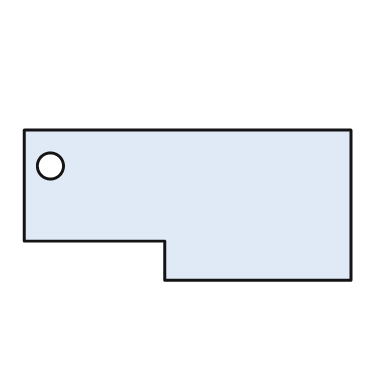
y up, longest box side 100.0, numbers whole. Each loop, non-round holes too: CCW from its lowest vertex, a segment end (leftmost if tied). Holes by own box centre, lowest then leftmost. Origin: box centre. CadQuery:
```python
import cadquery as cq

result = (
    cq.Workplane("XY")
    .moveTo(-7.0, -23.0)
    .lineTo(50.0, -23.0)
    .lineTo(50.0, 23.0)
    .lineTo(-50.0, 23.0)
    .lineTo(-50.0, -11.0)
    .lineTo(-7.0, -11.0)
    .close()
    .moveTo(-42.0, 12.0)
    .circle(4.0)
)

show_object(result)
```